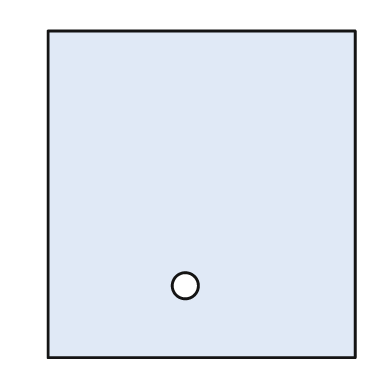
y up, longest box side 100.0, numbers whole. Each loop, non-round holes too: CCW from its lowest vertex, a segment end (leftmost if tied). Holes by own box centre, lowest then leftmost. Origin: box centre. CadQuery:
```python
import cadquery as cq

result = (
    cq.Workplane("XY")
    .moveTo(-47.0, -50.0)
    .lineTo(47.0, -50.0)
    .lineTo(47.0, 50.0)
    .lineTo(-47.0, 50.0)
    .close()
    .moveTo(-5.0, -28.0)
    .circle(4.0)
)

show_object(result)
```